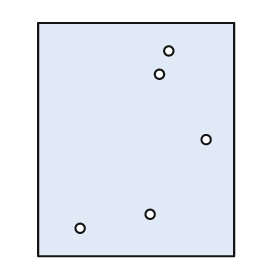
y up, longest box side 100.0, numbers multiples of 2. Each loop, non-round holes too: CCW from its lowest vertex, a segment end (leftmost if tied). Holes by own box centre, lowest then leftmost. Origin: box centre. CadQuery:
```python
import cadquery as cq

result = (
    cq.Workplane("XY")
    .moveTo(-42.0, -50.0)
    .lineTo(42.0, -50.0)
    .lineTo(42.0, 50.0)
    .lineTo(-42.0, 50.0)
    .close()
    .moveTo(-24.0, -38.0)
    .circle(2.0)
    .moveTo(6.0, -32.0)
    .circle(2.0)
    .moveTo(30.0, 0.0)
    .circle(2.0)
    .moveTo(10.0, 28.0)
    .circle(2.0)
    .moveTo(14.0, 38.0)
    .circle(2.0)
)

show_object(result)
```